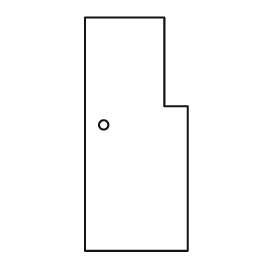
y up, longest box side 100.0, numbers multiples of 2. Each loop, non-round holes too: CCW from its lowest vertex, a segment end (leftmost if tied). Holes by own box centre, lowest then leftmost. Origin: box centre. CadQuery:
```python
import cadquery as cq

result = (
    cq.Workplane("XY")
    .moveTo(-22.0, -50.0)
    .lineTo(22.0, -50.0)
    .lineTo(22.0, 12.0)
    .lineTo(12.0, 12.0)
    .lineTo(12.0, 50.0)
    .lineTo(-22.0, 50.0)
    .close()
    .moveTo(-14.0, 4.0)
    .circle(2.0)
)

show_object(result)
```